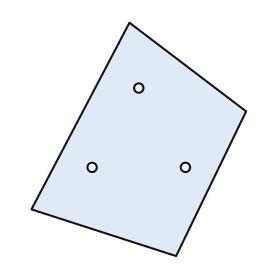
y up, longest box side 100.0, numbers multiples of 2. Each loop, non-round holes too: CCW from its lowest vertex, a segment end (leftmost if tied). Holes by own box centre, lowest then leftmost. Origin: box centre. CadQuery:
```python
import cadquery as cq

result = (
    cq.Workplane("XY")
    .moveTo(16.0, -50.0)
    .lineTo(46.0, 12.0)
    .lineTo(-4.0, 50.0)
    .lineTo(-46.0, -30.0)
    .close()
    .moveTo(-20.0, -12.0)
    .circle(2.0)
    .moveTo(20.0, -12.0)
    .circle(2.0)
    .moveTo(0.0, 22.0)
    .circle(2.0)
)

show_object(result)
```